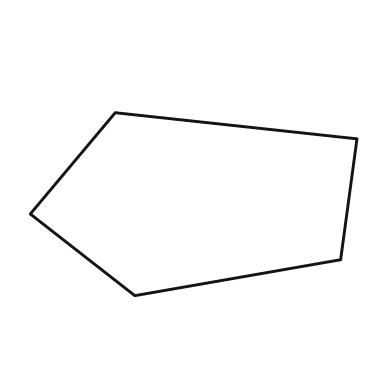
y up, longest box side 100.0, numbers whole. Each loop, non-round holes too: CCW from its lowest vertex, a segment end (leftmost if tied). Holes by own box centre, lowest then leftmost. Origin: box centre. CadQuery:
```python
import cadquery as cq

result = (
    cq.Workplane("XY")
    .moveTo(-18.0, -28.0)
    .lineTo(45.0, -17.0)
    .lineTo(50.0, 20.0)
    .lineTo(-24.0, 28.0)
    .lineTo(-50.0, -3.0)
    .close()
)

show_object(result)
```